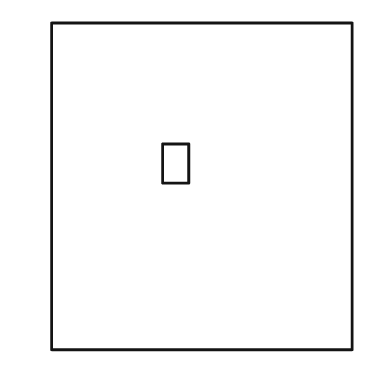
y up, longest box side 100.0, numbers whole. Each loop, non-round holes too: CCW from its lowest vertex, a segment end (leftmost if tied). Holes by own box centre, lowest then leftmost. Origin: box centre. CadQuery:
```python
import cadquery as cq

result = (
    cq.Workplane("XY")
    .moveTo(-46.0, -50.0)
    .lineTo(46.0, -50.0)
    .lineTo(46.0, 50.0)
    .lineTo(-46.0, 50.0)
    .close()
    .moveTo(-12.0, 1.0)
    .lineTo(-4.0, 1.0)
    .lineTo(-4.0, 13.0)
    .lineTo(-12.0, 13.0)
    .close()
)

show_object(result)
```